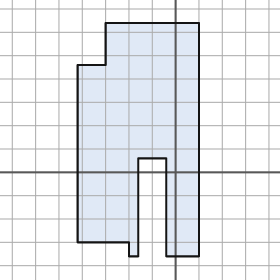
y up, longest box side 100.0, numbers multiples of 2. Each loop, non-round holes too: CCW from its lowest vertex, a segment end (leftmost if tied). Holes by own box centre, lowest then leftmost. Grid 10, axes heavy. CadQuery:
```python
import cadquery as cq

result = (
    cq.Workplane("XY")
    .moveTo(-20.0, -36.0)
    .lineTo(-16.0, -36.0)
    .lineTo(-16.0, 6.0)
    .lineTo(-4.0, 6.0)
    .lineTo(-4.0, -36.0)
    .lineTo(10.0, -36.0)
    .lineTo(10.0, 64.0)
    .lineTo(-30.0, 64.0)
    .lineTo(-30.0, 46.0)
    .lineTo(-42.0, 46.0)
    .lineTo(-42.0, -30.0)
    .lineTo(-20.0, -30.0)
    .close()
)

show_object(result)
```